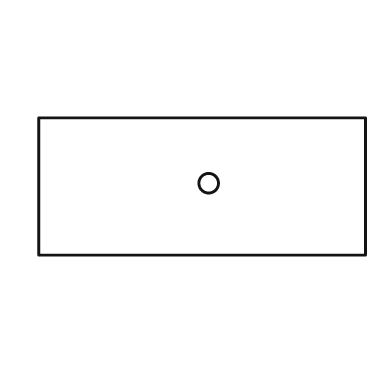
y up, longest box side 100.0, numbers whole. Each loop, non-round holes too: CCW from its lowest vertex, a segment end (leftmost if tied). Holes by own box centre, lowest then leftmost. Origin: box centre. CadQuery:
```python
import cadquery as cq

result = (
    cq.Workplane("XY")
    .moveTo(-50.0, -21.0)
    .lineTo(50.0, -21.0)
    .lineTo(50.0, 21.0)
    .lineTo(-50.0, 21.0)
    .close()
    .moveTo(2.0, 1.0)
    .circle(3.0)
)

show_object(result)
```